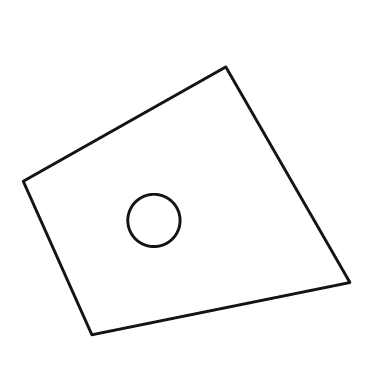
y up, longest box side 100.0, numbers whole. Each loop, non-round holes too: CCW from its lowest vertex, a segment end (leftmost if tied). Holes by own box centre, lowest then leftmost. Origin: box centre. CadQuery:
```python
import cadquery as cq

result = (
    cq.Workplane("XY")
    .moveTo(-29.0, -41.0)
    .lineTo(50.0, -25.0)
    .lineTo(12.0, 41.0)
    .lineTo(-50.0, 6.0)
    .close()
    .moveTo(-10.0, -6.0)
    .circle(8.0)
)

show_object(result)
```